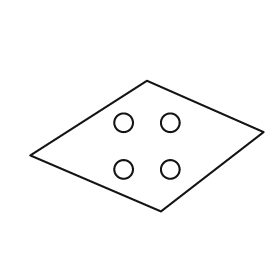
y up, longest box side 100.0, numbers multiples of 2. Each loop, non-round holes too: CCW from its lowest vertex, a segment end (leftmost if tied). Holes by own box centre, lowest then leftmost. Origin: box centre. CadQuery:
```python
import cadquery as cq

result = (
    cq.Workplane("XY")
    .moveTo(6.0, -28.0)
    .lineTo(50.0, 6.0)
    .lineTo(0.0, 28.0)
    .lineTo(-50.0, -4.0)
    .close()
    .moveTo(-10.0, -10.0)
    .circle(4.0)
    .moveTo(10.0, -10.0)
    .circle(4.0)
    .moveTo(-10.0, 10.0)
    .circle(4.0)
    .moveTo(10.0, 10.0)
    .circle(4.0)
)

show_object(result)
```